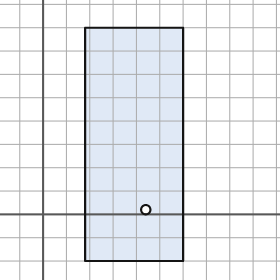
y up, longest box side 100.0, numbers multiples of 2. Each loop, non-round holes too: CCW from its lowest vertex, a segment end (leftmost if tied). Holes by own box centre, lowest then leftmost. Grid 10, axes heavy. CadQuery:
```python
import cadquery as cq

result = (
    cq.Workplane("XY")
    .moveTo(18.0, -20.0)
    .lineTo(60.0, -20.0)
    .lineTo(60.0, 80.0)
    .lineTo(18.0, 80.0)
    .close()
    .moveTo(44.0, 2.0)
    .circle(2.0)
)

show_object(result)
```